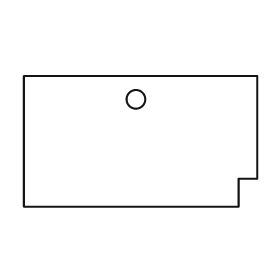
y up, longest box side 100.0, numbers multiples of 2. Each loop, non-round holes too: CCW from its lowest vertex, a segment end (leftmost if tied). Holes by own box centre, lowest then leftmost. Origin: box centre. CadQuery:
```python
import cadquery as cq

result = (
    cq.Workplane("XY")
    .moveTo(-50.0, -28.0)
    .lineTo(42.0, -28.0)
    .lineTo(42.0, -16.0)
    .lineTo(50.0, -16.0)
    .lineTo(50.0, 28.0)
    .lineTo(-50.0, 28.0)
    .close()
    .moveTo(-2.0, 18.0)
    .circle(4.0)
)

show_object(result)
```